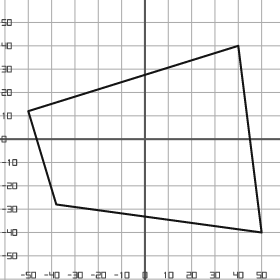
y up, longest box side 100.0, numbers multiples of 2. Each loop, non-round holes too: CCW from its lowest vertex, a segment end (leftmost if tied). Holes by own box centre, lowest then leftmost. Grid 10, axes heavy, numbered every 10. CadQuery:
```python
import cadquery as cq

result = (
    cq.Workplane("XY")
    .moveTo(50.0, -40.0)
    .lineTo(40.0, 40.0)
    .lineTo(-50.0, 12.0)
    .lineTo(-38.0, -28.0)
    .close()
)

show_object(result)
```